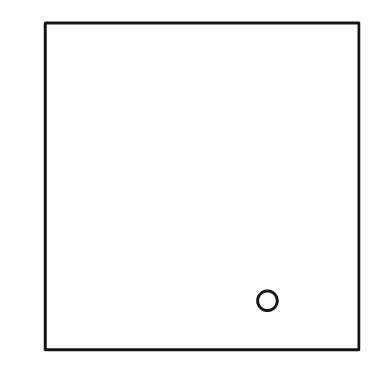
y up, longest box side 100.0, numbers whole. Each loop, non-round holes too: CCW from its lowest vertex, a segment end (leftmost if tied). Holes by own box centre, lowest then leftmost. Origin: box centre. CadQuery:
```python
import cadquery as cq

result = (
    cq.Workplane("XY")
    .moveTo(-48.0, -50.0)
    .lineTo(48.0, -50.0)
    .lineTo(48.0, 50.0)
    .lineTo(-48.0, 50.0)
    .close()
    .moveTo(20.0, -35.0)
    .circle(3.0)
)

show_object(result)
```